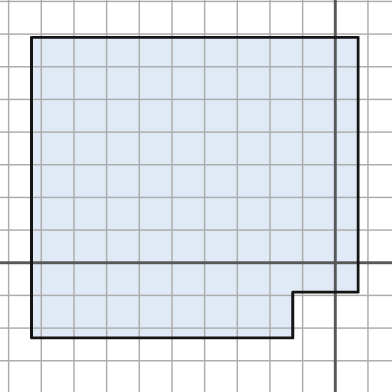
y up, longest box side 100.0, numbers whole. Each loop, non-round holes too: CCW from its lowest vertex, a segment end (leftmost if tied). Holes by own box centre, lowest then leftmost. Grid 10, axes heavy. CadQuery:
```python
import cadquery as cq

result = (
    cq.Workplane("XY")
    .moveTo(-93.0, -23.0)
    .lineTo(-13.0, -23.0)
    .lineTo(-13.0, -9.0)
    .lineTo(7.0, -9.0)
    .lineTo(7.0, 69.0)
    .lineTo(-93.0, 69.0)
    .close()
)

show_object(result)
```